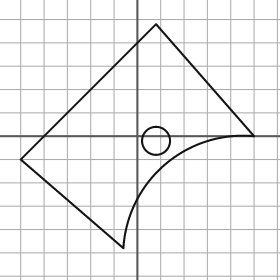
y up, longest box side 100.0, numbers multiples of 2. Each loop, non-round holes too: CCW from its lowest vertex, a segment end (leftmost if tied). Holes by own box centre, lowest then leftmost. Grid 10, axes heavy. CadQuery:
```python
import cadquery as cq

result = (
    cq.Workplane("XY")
    .moveTo(-6.0, -48.0)
    .threePointArc((12.0, -12.0), (50.0, 0.0))
    .lineTo(8.0, 48.0)
    .lineTo(-50.0, -10.0)
    .close()
    .moveTo(8.0, -2.0)
    .circle(6.0)
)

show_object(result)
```